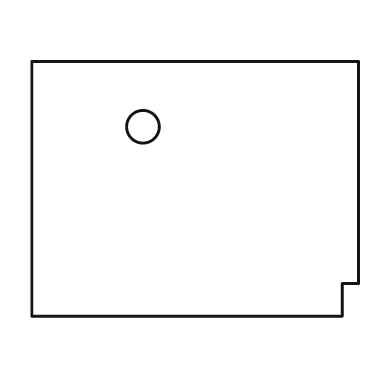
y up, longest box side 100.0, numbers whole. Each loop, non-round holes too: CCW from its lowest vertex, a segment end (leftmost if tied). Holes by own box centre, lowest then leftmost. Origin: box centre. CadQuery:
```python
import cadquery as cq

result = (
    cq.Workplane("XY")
    .moveTo(-50.0, -39.0)
    .lineTo(45.0, -39.0)
    .lineTo(45.0, -29.0)
    .lineTo(50.0, -29.0)
    .lineTo(50.0, 39.0)
    .lineTo(-50.0, 39.0)
    .close()
    .moveTo(-16.0, 19.0)
    .circle(5.0)
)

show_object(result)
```